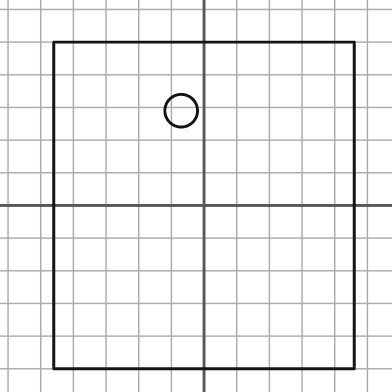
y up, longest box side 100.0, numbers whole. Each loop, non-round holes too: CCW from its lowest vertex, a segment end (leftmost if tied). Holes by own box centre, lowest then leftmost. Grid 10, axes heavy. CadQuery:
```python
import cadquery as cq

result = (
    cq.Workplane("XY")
    .moveTo(-46.0, -50.0)
    .lineTo(46.0, -50.0)
    .lineTo(46.0, 50.0)
    .lineTo(-46.0, 50.0)
    .close()
    .moveTo(-7.0, 29.0)
    .circle(5.0)
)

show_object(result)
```